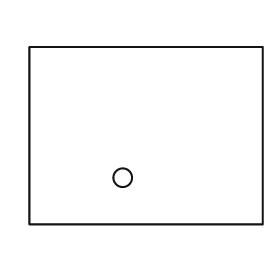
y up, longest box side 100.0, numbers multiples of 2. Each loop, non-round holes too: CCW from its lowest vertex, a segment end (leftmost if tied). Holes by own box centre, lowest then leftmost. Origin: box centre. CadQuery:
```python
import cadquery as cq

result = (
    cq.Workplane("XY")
    .moveTo(-50.0, -38.0)
    .lineTo(50.0, -38.0)
    .lineTo(50.0, 38.0)
    .lineTo(-50.0, 38.0)
    .close()
    .moveTo(-10.0, -18.0)
    .circle(4.0)
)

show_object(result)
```